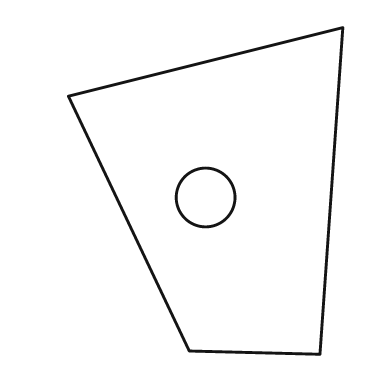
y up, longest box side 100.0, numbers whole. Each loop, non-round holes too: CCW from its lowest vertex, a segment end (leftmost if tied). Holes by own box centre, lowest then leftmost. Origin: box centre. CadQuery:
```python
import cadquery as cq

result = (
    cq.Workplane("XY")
    .moveTo(35.0, -50.0)
    .lineTo(42.0, 50.0)
    .lineTo(-42.0, 29.0)
    .lineTo(-5.0, -49.0)
    .close()
    .moveTo(0.0, -2.0)
    .circle(9.0)
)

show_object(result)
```